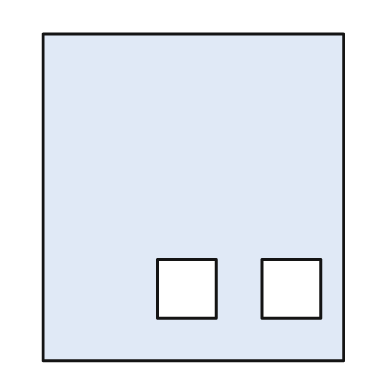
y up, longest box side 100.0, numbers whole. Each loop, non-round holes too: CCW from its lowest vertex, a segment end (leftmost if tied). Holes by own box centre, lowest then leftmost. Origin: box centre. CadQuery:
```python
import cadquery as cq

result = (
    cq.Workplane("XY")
    .moveTo(-46.0, -50.0)
    .lineTo(46.0, -50.0)
    .lineTo(46.0, 50.0)
    .lineTo(-46.0, 50.0)
    .close()
    .moveTo(-11.0, -37.0)
    .lineTo(7.0, -37.0)
    .lineTo(7.0, -19.0)
    .lineTo(-11.0, -19.0)
    .close()
    .moveTo(21.0, -37.0)
    .lineTo(39.0, -37.0)
    .lineTo(39.0, -19.0)
    .lineTo(21.0, -19.0)
    .close()
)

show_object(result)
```